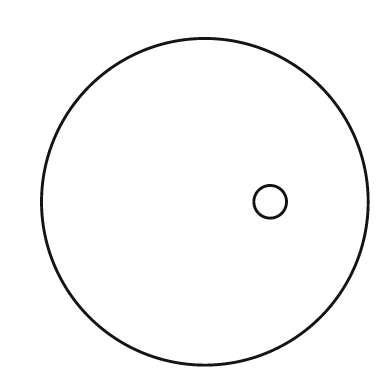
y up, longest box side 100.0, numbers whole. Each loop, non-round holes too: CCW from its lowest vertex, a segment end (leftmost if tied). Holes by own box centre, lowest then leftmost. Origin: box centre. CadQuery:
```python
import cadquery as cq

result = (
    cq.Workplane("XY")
    .moveTo(0.0, 0.0)
    .circle(50.0)
    .moveTo(20.0, 0.0)
    .circle(5.0)
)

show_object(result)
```